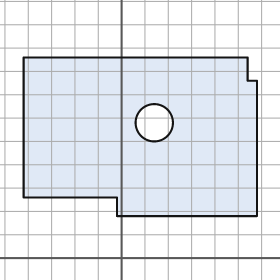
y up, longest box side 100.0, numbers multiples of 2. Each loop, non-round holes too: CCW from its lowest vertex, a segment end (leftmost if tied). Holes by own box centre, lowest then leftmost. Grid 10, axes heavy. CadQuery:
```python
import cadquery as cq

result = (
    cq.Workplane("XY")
    .moveTo(-2.0, 18.0)
    .lineTo(58.0, 18.0)
    .lineTo(58.0, 76.0)
    .lineTo(54.0, 76.0)
    .lineTo(54.0, 86.0)
    .lineTo(-42.0, 86.0)
    .lineTo(-42.0, 26.0)
    .lineTo(-2.0, 26.0)
    .close()
    .moveTo(14.0, 58.0)
    .circle(8.0)
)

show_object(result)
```